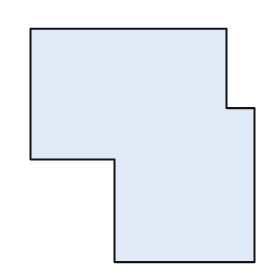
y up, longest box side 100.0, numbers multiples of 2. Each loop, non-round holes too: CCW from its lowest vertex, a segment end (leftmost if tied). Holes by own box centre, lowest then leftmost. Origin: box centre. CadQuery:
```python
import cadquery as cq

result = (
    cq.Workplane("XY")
    .moveTo(-12.0, -50.0)
    .lineTo(48.0, -50.0)
    .lineTo(48.0, 16.0)
    .lineTo(36.0, 16.0)
    .lineTo(36.0, 50.0)
    .lineTo(-48.0, 50.0)
    .lineTo(-48.0, -6.0)
    .lineTo(-12.0, -6.0)
    .close()
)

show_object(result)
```